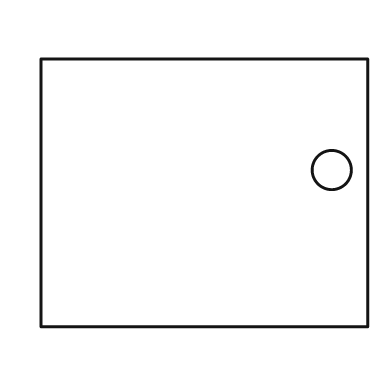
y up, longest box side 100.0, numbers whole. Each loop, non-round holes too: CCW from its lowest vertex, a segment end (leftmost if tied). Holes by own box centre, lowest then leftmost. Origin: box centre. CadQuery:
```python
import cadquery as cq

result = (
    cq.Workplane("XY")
    .moveTo(-50.0, -41.0)
    .lineTo(50.0, -41.0)
    .lineTo(50.0, 41.0)
    .lineTo(-50.0, 41.0)
    .close()
    .moveTo(39.0, 7.0)
    .circle(6.0)
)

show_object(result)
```